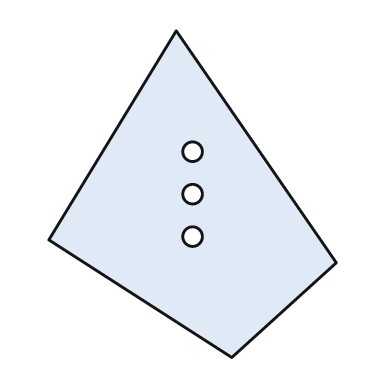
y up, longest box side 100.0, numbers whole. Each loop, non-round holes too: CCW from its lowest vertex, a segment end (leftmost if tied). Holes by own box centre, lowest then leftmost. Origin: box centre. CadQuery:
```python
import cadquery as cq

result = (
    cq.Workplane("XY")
    .moveTo(12.0, -50.0)
    .lineTo(44.0, -21.0)
    .lineTo(-5.0, 50.0)
    .lineTo(-44.0, -14.0)
    .close()
    .moveTo(0.0, -13.0)
    .circle(3.0)
    .moveTo(0.0, 0.0)
    .circle(3.0)
    .moveTo(0.0, 13.0)
    .circle(3.0)
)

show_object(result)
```